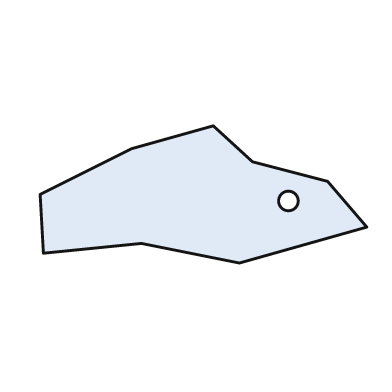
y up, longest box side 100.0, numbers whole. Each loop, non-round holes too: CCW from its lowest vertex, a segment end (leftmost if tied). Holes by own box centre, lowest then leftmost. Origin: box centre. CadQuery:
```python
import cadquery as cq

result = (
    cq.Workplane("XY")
    .moveTo(11.0, -21.0)
    .lineTo(50.0, -10.0)
    .lineTo(38.0, 4.0)
    .lineTo(15.0, 10.0)
    .lineTo(3.0, 21.0)
    .lineTo(-22.0, 14.0)
    .lineTo(-50.0, 0.0)
    .lineTo(-49.0, -18.0)
    .lineTo(-19.0, -15.0)
    .close()
    .moveTo(26.0, -2.0)
    .circle(3.0)
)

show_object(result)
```